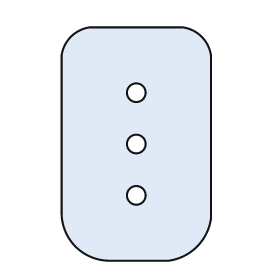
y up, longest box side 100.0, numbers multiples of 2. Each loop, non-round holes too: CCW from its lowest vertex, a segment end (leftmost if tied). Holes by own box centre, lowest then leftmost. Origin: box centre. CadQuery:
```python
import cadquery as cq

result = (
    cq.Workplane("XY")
    .moveTo(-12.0, -50.0)
    .lineTo(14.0, -50.0)
    .threePointArc((26.0, -44.0), (32.0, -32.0))
    .lineTo(32.0, 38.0)
    .threePointArc((28.0, 46.0), (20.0, 50.0))
    .lineTo(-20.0, 50.0)
    .threePointArc((-28.0, 46.0), (-32.0, 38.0))
    .lineTo(-32.0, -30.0)
    .threePointArc((-26.0, -44.0), (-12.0, -50.0))
    .close()
    .moveTo(0.0, -22.0)
    .circle(4.0)
    .moveTo(0.0, 0.0)
    .circle(4.0)
    .moveTo(0.0, 22.0)
    .circle(4.0)
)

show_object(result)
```